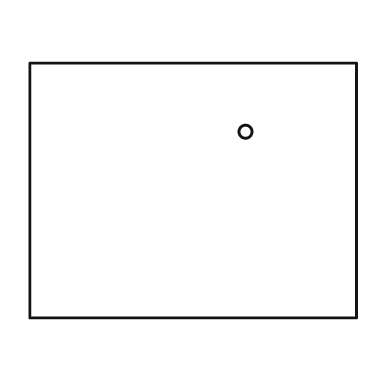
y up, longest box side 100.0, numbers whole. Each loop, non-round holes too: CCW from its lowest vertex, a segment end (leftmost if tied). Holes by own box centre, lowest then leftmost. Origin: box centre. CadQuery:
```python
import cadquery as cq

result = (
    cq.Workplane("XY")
    .moveTo(-50.0, -39.0)
    .lineTo(50.0, -39.0)
    .lineTo(50.0, 39.0)
    .lineTo(-50.0, 39.0)
    .close()
    .moveTo(16.0, 18.0)
    .circle(2.0)
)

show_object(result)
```